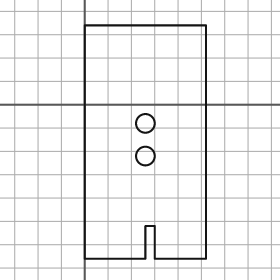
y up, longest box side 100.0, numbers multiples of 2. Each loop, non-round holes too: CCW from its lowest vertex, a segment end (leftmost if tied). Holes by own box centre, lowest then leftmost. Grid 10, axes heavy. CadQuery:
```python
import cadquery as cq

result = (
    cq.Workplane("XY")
    .moveTo(0.0, -66.0)
    .lineTo(26.0, -66.0)
    .lineTo(26.0, -52.0)
    .lineTo(30.0, -52.0)
    .lineTo(30.0, -66.0)
    .lineTo(52.0, -66.0)
    .lineTo(52.0, 34.0)
    .lineTo(0.0, 34.0)
    .close()
    .moveTo(26.0, -22.0)
    .circle(4.0)
    .moveTo(26.0, -8.0)
    .circle(4.0)
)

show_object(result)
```